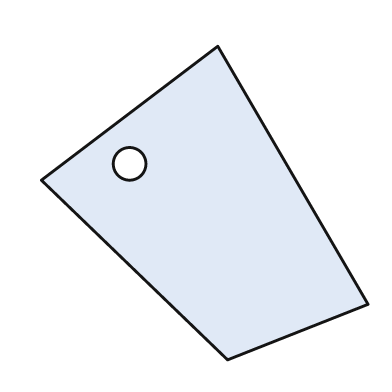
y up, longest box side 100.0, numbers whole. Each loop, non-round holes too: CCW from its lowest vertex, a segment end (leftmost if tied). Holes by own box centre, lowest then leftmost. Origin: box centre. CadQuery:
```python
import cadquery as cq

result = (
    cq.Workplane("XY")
    .moveTo(7.0, -48.0)
    .lineTo(50.0, -31.0)
    .lineTo(4.0, 48.0)
    .lineTo(-50.0, 7.0)
    .close()
    .moveTo(-23.0, 12.0)
    .circle(5.0)
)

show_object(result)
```